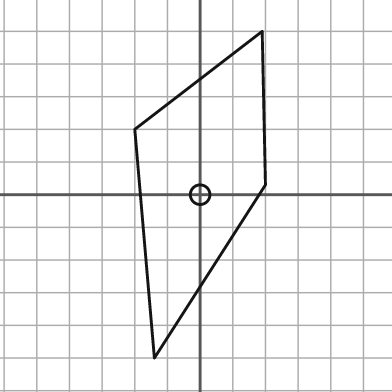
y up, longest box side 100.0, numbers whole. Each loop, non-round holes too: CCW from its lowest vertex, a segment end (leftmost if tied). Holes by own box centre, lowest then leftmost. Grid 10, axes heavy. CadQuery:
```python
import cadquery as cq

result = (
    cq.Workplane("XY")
    .moveTo(-14.0, -50.0)
    .lineTo(20.0, 3.0)
    .lineTo(19.0, 50.0)
    .lineTo(-20.0, 20.0)
    .close()
    .moveTo(0.0, 0.0)
    .circle(3.0)
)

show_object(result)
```